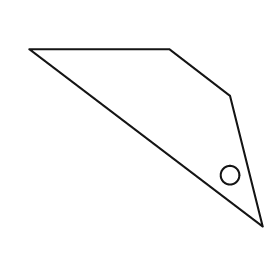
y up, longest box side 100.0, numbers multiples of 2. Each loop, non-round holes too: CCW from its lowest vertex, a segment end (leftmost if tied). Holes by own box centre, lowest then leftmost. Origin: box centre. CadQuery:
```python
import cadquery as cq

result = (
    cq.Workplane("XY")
    .moveTo(50.0, -38.0)
    .lineTo(36.0, 18.0)
    .lineTo(10.0, 38.0)
    .lineTo(-50.0, 38.0)
    .close()
    .moveTo(36.0, -16.0)
    .circle(4.0)
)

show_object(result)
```